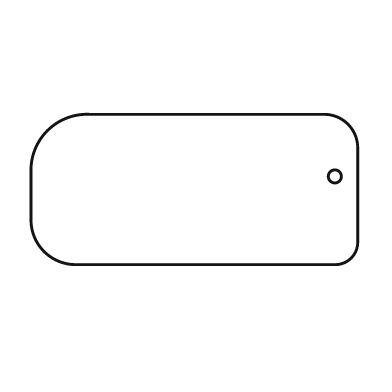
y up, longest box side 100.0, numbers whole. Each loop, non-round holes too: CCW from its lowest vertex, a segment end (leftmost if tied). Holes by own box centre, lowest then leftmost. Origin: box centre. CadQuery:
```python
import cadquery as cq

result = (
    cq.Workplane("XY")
    .moveTo(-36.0, -23.0)
    .lineTo(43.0, -23.0)
    .threePointArc((48.0, -21.0), (50.0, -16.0))
    .lineTo(50.0, 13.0)
    .threePointArc((47.0, 20.0), (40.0, 23.0))
    .lineTo(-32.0, 23.0)
    .threePointArc((-45.0, 18.0), (-50.0, 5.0))
    .lineTo(-50.0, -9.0)
    .threePointArc((-46.0, -19.0), (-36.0, -23.0))
    .close()
    .moveTo(43.0, 4.0)
    .circle(2.0)
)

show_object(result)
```